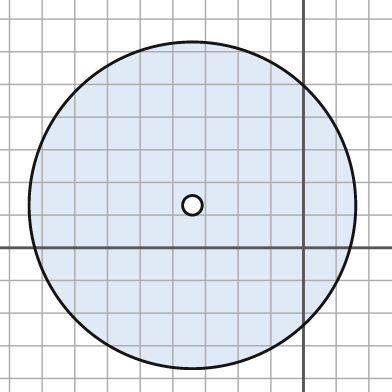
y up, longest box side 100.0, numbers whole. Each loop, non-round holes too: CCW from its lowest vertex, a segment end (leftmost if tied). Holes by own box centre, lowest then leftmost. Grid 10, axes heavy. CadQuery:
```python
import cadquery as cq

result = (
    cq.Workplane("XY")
    .moveTo(-34.0, 13.0)
    .circle(50.0)
    .moveTo(-34.0, 13.0)
    .circle(3.0)
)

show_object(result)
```